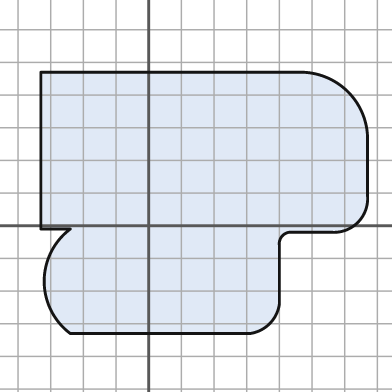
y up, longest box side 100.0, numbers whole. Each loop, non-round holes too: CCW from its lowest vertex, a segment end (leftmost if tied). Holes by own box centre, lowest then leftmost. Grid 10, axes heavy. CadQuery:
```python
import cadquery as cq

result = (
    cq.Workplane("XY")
    .moveTo(-24.0, -33.0)
    .lineTo(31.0, -33.0)
    .threePointArc((37.0, -30.0), (40.0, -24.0))
    .lineTo(40.0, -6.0)
    .threePointArc((41.0, -3.0), (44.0, -2.0))
    .lineTo(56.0, -2.0)
    .threePointArc((64.0, 1.0), (67.0, 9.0))
    .lineTo(67.0, 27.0)
    .threePointArc((61.0, 41.0), (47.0, 47.0))
    .lineTo(-33.0, 47.0)
    .lineTo(-33.0, -1.0)
    .lineTo(-24.0, -1.0)
    .threePointArc((-32.0, -17.0), (-24.0, -33.0))
    .close()
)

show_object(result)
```